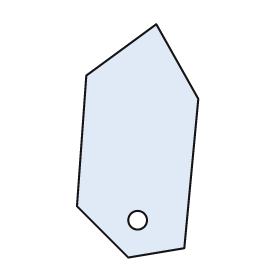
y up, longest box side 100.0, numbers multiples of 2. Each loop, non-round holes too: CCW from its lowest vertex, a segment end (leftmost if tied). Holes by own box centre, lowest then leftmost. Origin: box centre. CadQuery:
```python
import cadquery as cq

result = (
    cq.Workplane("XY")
    .moveTo(-4.0, -50.0)
    .lineTo(20.0, -46.0)
    .lineTo(26.0, 18.0)
    .lineTo(8.0, 50.0)
    .lineTo(-22.0, 28.0)
    .lineTo(-26.0, -28.0)
    .close()
    .moveTo(0.0, -34.0)
    .circle(4.0)
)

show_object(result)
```